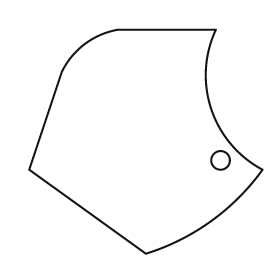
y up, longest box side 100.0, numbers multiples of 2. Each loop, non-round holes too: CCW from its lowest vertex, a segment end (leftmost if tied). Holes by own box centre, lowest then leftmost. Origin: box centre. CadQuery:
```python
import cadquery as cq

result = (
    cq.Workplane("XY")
    .moveTo(0.0, -48.0)
    .threePointArc((28.0, -34.0), (50.0, -12.0))
    .threePointArc((28.0, 14.0), (30.0, 48.0))
    .lineTo(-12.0, 48.0)
    .threePointArc((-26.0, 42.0), (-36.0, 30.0))
    .lineTo(-50.0, -12.0)
    .close()
    .moveTo(32.0, -8.0)
    .circle(4.0)
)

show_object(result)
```